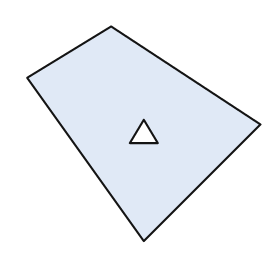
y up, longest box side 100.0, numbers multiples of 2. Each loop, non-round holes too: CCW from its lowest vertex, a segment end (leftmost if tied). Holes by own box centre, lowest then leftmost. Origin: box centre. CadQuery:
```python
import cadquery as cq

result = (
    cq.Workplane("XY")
    .moveTo(0.0, -46.0)
    .lineTo(50.0, 4.0)
    .lineTo(-14.0, 46.0)
    .lineTo(-50.0, 24.0)
    .close()
    .moveTo(-6.0, -4.0)
    .lineTo(6.0, -4.0)
    .lineTo(0.0, 6.0)
    .close()
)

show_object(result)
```